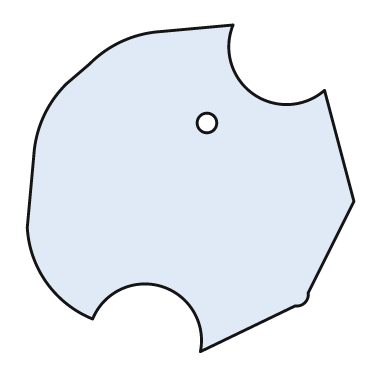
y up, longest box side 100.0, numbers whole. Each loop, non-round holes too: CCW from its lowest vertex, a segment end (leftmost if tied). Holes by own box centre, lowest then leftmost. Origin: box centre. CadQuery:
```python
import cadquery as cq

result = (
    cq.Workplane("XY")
    .moveTo(3.0, -50.0)
    .lineTo(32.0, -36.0)
    .threePointArc((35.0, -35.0), (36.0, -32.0))
    .lineTo(50.0, -4.0)
    .lineTo(41.0, 30.0)
    .threePointArc((19.0, 29.0), (13.0, 50.0))
    .lineTo(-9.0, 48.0)
    .threePointArc((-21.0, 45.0), (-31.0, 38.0))
    .lineTo(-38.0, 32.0)
    .threePointArc((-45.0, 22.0), (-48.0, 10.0))
    .lineTo(-50.0, -12.0)
    .threePointArc((-44.0, -29.0), (-30.0, -40.0))
    .threePointArc((-9.0, -30.0), (3.0, -50.0))
    .close()
    .moveTo(5.0, 20.0)
    .circle(3.0)
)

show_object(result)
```